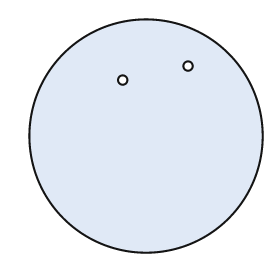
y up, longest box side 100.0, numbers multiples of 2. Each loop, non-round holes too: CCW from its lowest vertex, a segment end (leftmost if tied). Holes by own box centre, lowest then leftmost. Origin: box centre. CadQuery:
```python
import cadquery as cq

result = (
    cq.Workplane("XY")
    .moveTo(0.0, 0.0)
    .circle(50.0)
    .moveTo(-10.0, 24.0)
    .circle(2.0)
    .moveTo(18.0, 30.0)
    .circle(2.0)
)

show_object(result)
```